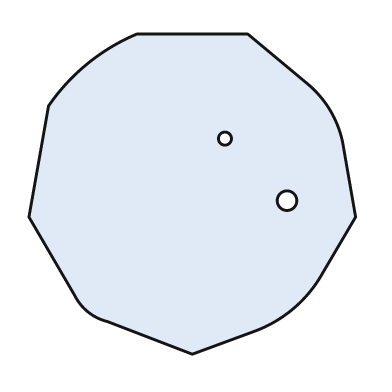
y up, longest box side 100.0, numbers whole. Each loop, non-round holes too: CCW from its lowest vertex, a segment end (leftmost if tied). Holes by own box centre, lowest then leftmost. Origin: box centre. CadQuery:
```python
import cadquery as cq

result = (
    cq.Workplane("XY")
    .moveTo(0.0, -49.0)
    .lineTo(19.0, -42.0)
    .threePointArc((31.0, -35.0), (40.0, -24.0))
    .lineTo(50.0, -7.0)
    .lineTo(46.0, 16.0)
    .threePointArc((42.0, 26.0), (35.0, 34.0))
    .lineTo(17.0, 49.0)
    .lineTo(-17.0, 49.0)
    .threePointArc((-32.0, 40.0), (-44.0, 27.0))
    .lineTo(-50.0, -7.0)
    .lineTo(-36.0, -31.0)
    .threePointArc((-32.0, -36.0), (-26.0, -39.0))
    .close()
    .moveTo(29.0, -2.0)
    .circle(3.0)
    .moveTo(10.0, 17.0)
    .circle(2.0)
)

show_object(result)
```